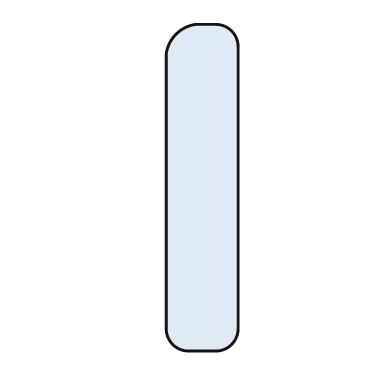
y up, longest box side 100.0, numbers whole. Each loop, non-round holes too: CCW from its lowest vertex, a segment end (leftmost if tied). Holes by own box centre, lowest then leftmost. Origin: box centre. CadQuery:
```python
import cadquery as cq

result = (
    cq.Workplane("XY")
    .moveTo(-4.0, -50.0)
    .lineTo(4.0, -50.0)
    .threePointArc((9.0, -48.0), (11.0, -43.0))
    .lineTo(11.0, 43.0)
    .threePointArc((9.0, 48.0), (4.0, 50.0))
    .lineTo(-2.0, 50.0)
    .threePointArc((-8.0, 47.0), (-11.0, 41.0))
    .lineTo(-11.0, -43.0)
    .threePointArc((-9.0, -48.0), (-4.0, -50.0))
    .close()
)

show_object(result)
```